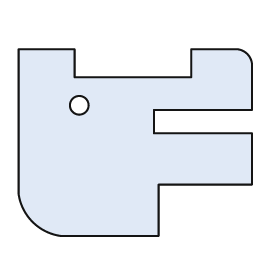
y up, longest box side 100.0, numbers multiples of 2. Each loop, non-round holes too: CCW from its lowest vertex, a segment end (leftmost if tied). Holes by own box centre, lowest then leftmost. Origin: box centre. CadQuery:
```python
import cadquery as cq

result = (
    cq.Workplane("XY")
    .moveTo(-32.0, -40.0)
    .lineTo(10.0, -40.0)
    .lineTo(10.0, -18.0)
    .lineTo(50.0, -18.0)
    .lineTo(50.0, 4.0)
    .lineTo(8.0, 4.0)
    .lineTo(8.0, 14.0)
    .lineTo(50.0, 14.0)
    .lineTo(50.0, 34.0)
    .threePointArc((48.0, 38.0), (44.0, 40.0))
    .lineTo(24.0, 40.0)
    .lineTo(24.0, 28.0)
    .lineTo(-26.0, 28.0)
    .lineTo(-26.0, 40.0)
    .lineTo(-50.0, 40.0)
    .lineTo(-50.0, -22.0)
    .threePointArc((-44.0, -34.0), (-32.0, -40.0))
    .close()
    .moveTo(-24.0, 16.0)
    .circle(4.0)
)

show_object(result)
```